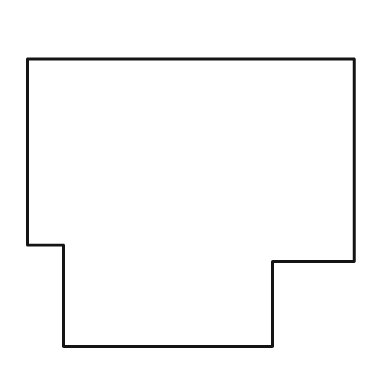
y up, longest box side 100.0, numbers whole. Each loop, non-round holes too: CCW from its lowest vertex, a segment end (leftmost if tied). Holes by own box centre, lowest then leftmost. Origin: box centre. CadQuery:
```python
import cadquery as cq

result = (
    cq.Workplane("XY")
    .moveTo(-39.0, -44.0)
    .lineTo(25.0, -44.0)
    .lineTo(25.0, -18.0)
    .lineTo(50.0, -18.0)
    .lineTo(50.0, 44.0)
    .lineTo(-50.0, 44.0)
    .lineTo(-50.0, -13.0)
    .lineTo(-39.0, -13.0)
    .close()
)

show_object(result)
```